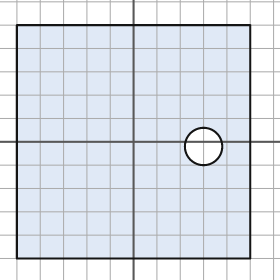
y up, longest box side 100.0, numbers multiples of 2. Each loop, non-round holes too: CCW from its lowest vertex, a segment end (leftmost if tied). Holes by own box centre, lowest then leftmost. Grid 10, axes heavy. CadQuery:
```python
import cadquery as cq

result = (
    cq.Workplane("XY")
    .moveTo(-50.0, -50.0)
    .lineTo(50.0, -50.0)
    .lineTo(50.0, 50.0)
    .lineTo(-50.0, 50.0)
    .close()
    .moveTo(30.0, -2.0)
    .circle(8.0)
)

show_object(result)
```